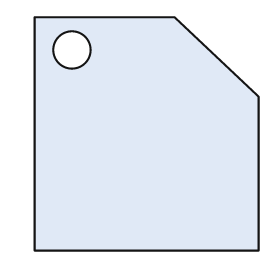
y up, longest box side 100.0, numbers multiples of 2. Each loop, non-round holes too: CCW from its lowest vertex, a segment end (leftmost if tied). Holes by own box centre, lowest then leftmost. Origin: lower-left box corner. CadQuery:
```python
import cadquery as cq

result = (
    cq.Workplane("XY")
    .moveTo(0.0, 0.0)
    .lineTo(96.0, 0.0)
    .lineTo(96.0, 66.0)
    .lineTo(60.0, 100.0)
    .lineTo(0.0, 100.0)
    .close()
    .moveTo(16.0, 86.0)
    .circle(8.0)
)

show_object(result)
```